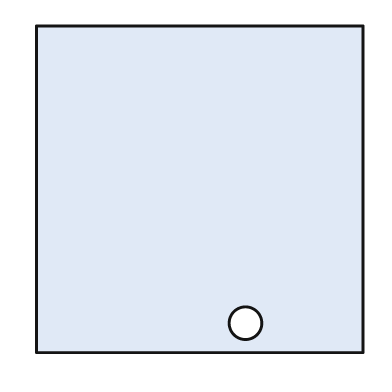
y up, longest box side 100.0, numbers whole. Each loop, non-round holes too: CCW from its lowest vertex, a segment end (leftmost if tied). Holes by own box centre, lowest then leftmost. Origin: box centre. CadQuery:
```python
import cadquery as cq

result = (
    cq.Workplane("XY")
    .moveTo(-50.0, -50.0)
    .lineTo(50.0, -50.0)
    .lineTo(50.0, 50.0)
    .lineTo(-50.0, 50.0)
    .close()
    .moveTo(14.0, -41.0)
    .circle(5.0)
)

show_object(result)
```